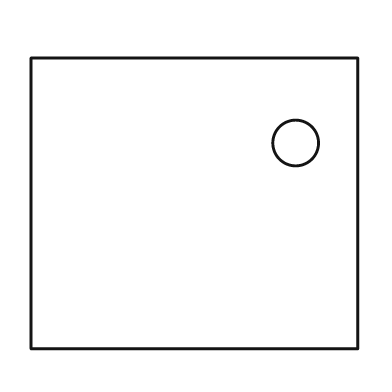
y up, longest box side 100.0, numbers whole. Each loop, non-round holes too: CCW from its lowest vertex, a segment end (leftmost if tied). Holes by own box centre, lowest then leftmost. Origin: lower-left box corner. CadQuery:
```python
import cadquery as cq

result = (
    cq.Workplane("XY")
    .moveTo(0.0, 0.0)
    .lineTo(100.0, 0.0)
    .lineTo(100.0, 89.0)
    .lineTo(0.0, 89.0)
    .close()
    .moveTo(81.0, 63.0)
    .circle(7.0)
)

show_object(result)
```